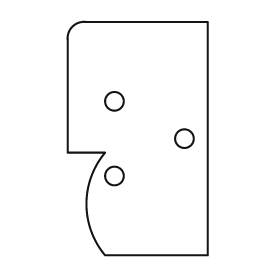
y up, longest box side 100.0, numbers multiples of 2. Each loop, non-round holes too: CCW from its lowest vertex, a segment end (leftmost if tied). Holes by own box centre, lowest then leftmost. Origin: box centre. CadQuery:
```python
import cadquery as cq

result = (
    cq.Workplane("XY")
    .moveTo(-14.0, -50.0)
    .lineTo(30.0, -50.0)
    .lineTo(30.0, 50.0)
    .lineTo(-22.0, 50.0)
    .threePointArc((-28.0, 48.0), (-30.0, 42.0))
    .lineTo(-30.0, -6.0)
    .lineTo(-14.0, -6.0)
    .threePointArc((-22.0, -28.0), (-14.0, -50.0))
    .close()
    .moveTo(-10.0, -16.0)
    .circle(4.0)
    .moveTo(20.0, 0.0)
    .circle(4.0)
    .moveTo(-10.0, 16.0)
    .circle(4.0)
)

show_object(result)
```